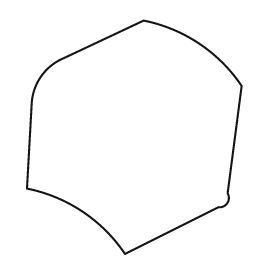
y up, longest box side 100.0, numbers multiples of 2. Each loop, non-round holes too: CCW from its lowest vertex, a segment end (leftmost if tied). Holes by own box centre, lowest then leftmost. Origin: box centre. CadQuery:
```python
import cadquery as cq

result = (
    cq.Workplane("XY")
    .moveTo(-4.0, -50.0)
    .lineTo(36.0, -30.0)
    .threePointArc((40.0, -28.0), (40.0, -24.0))
    .lineTo(46.0, 22.0)
    .threePointArc((28.0, 40.0), (4.0, 50.0))
    .lineTo(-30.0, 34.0)
    .threePointArc((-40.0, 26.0), (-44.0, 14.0))
    .lineTo(-46.0, -22.0)
    .threePointArc((-22.0, -32.0), (-4.0, -50.0))
    .close()
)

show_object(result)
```